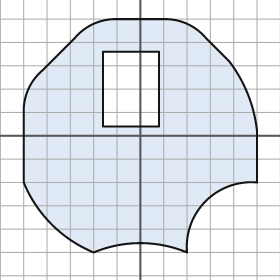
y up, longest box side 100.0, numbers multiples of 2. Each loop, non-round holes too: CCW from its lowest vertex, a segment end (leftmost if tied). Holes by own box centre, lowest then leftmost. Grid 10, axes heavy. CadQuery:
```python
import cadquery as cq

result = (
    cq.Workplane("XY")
    .moveTo(-20.0, -50.0)
    .threePointArc((0.0, -46.0), (20.0, -50.0))
    .threePointArc((28.0, -28.0), (50.0, -20.0))
    .lineTo(50.0, 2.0)
    .threePointArc((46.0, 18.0), (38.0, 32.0))
    .lineTo(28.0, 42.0)
    .threePointArc((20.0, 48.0), (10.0, 50.0))
    .lineTo(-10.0, 50.0)
    .threePointArc((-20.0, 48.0), (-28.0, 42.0))
    .lineTo(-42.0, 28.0)
    .threePointArc((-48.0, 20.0), (-50.0, 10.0))
    .lineTo(-50.0, -20.0)
    .threePointArc((-38.0, -38.0), (-20.0, -50.0))
    .close()
    .moveTo(-16.0, 4.0)
    .lineTo(8.0, 4.0)
    .lineTo(8.0, 36.0)
    .lineTo(-16.0, 36.0)
    .close()
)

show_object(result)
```